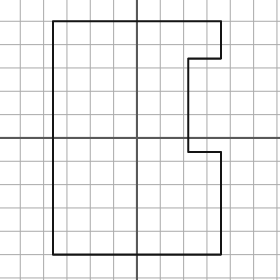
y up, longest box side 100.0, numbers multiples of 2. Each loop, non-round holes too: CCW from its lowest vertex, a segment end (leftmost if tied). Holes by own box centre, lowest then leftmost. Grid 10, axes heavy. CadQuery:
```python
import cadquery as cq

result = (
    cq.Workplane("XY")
    .moveTo(-36.0, -50.0)
    .lineTo(36.0, -50.0)
    .lineTo(36.0, -6.0)
    .lineTo(22.0, -6.0)
    .lineTo(22.0, 34.0)
    .lineTo(36.0, 34.0)
    .lineTo(36.0, 50.0)
    .lineTo(-36.0, 50.0)
    .close()
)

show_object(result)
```